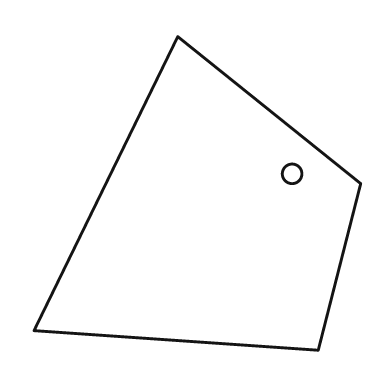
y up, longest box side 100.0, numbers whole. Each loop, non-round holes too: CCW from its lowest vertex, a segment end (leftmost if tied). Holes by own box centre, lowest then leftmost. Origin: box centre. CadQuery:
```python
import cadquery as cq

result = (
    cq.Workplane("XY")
    .moveTo(37.0, -48.0)
    .lineTo(50.0, 3.0)
    .lineTo(-6.0, 48.0)
    .lineTo(-50.0, -42.0)
    .close()
    .moveTo(29.0, 6.0)
    .circle(3.0)
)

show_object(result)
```